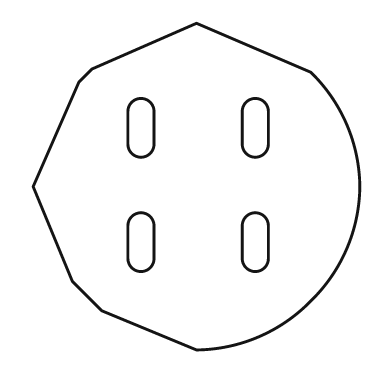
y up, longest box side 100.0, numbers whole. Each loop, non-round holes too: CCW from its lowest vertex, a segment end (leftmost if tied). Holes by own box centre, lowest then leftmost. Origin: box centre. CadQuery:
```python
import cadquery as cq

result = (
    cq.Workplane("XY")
    .moveTo(0.0, -50.0)
    .threePointArc((19.0, -46.0), (35.0, -35.0))
    .threePointArc((46.0, -19.0), (50.0, 0.0))
    .threePointArc((46.0, 19.0), (35.0, 35.0))
    .lineTo(0.0, 50.0)
    .lineTo(-32.0, 36.0)
    .lineTo(-36.0, 32.0)
    .lineTo(-50.0, 0.0)
    .lineTo(-38.0, -29.0)
    .lineTo(-29.0, -38.0)
    .close()
    .moveTo(-21.0, -22.0)
    .threePointArc((-17.0, -26.0), (-13.0, -22.0))
    .lineTo(-13.0, -12.0)
    .threePointArc((-17.0, -8.0), (-21.0, -12.0))
    .close()
    .moveTo(14.0, -22.0)
    .threePointArc((18.0, -26.0), (22.0, -22.0))
    .lineTo(22.0, -12.0)
    .threePointArc((18.0, -8.0), (14.0, -12.0))
    .close()
    .moveTo(-21.0, 13.0)
    .threePointArc((-17.0, 9.0), (-13.0, 13.0))
    .lineTo(-13.0, 23.0)
    .threePointArc((-17.0, 27.0), (-21.0, 23.0))
    .close()
    .moveTo(14.0, 13.0)
    .threePointArc((18.0, 9.0), (22.0, 13.0))
    .lineTo(22.0, 23.0)
    .threePointArc((18.0, 27.0), (14.0, 23.0))
    .close()
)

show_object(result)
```